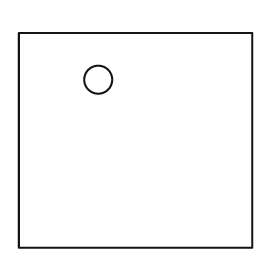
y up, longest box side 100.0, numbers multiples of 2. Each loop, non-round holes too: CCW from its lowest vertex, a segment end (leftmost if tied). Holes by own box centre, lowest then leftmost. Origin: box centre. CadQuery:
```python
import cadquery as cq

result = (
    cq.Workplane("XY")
    .moveTo(-50.0, -46.0)
    .lineTo(50.0, -46.0)
    .lineTo(50.0, 46.0)
    .lineTo(-50.0, 46.0)
    .close()
    .moveTo(-16.0, 26.0)
    .circle(6.0)
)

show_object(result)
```